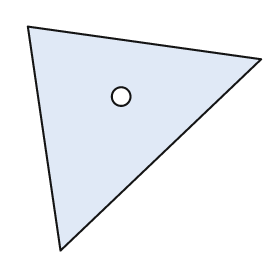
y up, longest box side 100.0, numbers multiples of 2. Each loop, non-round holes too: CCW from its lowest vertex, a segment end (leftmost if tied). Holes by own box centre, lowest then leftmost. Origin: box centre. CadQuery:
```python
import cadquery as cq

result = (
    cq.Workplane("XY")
    .moveTo(-36.0, -48.0)
    .lineTo(50.0, 34.0)
    .lineTo(-50.0, 48.0)
    .close()
    .moveTo(-10.0, 18.0)
    .circle(4.0)
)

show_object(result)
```